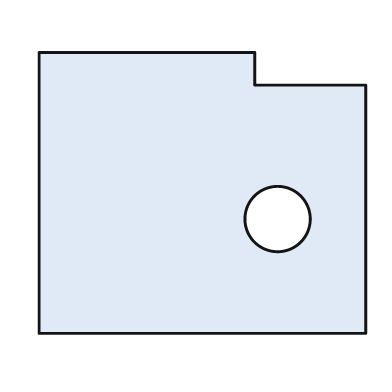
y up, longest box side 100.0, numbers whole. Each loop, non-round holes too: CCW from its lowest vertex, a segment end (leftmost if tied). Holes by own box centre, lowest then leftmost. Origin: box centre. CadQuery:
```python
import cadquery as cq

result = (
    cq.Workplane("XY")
    .moveTo(-50.0, -43.0)
    .lineTo(50.0, -43.0)
    .lineTo(50.0, 33.0)
    .lineTo(16.0, 33.0)
    .lineTo(16.0, 43.0)
    .lineTo(-50.0, 43.0)
    .close()
    .moveTo(23.0, -8.0)
    .circle(10.0)
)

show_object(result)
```